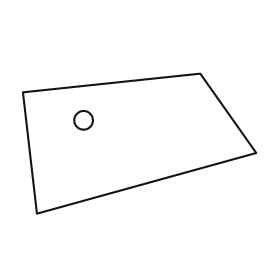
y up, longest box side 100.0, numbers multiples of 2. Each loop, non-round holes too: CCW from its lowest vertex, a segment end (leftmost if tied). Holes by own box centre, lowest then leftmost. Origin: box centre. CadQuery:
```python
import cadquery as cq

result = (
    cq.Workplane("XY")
    .moveTo(-44.0, -30.0)
    .lineTo(50.0, -4.0)
    .lineTo(26.0, 30.0)
    .lineTo(-50.0, 22.0)
    .close()
    .moveTo(-24.0, 10.0)
    .circle(4.0)
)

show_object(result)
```